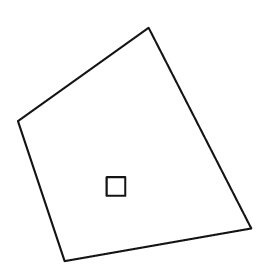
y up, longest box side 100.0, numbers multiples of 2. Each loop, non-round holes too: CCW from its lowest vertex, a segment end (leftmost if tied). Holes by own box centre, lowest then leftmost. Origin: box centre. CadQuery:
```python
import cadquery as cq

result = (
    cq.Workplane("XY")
    .moveTo(-30.0, -50.0)
    .lineTo(50.0, -36.0)
    .lineTo(6.0, 50.0)
    .lineTo(-50.0, 10.0)
    .close()
    .moveTo(-12.0, -22.0)
    .lineTo(-4.0, -22.0)
    .lineTo(-4.0, -14.0)
    .lineTo(-12.0, -14.0)
    .close()
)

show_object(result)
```